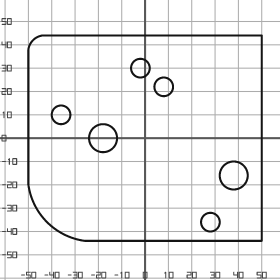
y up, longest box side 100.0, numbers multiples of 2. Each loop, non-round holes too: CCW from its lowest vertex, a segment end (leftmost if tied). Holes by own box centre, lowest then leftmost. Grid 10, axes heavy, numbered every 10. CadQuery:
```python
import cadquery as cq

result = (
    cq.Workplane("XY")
    .moveTo(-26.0, -44.0)
    .lineTo(50.0, -44.0)
    .lineTo(50.0, 44.0)
    .lineTo(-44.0, 44.0)
    .threePointArc((-48.0, 42.0), (-50.0, 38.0))
    .lineTo(-50.0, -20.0)
    .threePointArc((-42.0, -36.0), (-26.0, -44.0))
    .close()
    .moveTo(28.0, -36.0)
    .circle(4.0)
    .moveTo(38.0, -16.0)
    .circle(6.0)
    .moveTo(-18.0, 0.0)
    .circle(6.0)
    .moveTo(-36.0, 10.0)
    .circle(4.0)
    .moveTo(8.0, 22.0)
    .circle(4.0)
    .moveTo(-2.0, 30.0)
    .circle(4.0)
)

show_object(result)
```